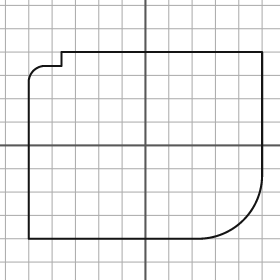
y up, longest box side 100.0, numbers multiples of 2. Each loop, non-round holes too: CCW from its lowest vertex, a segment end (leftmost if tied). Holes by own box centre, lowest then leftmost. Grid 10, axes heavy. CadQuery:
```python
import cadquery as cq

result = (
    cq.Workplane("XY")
    .moveTo(-50.0, -40.0)
    .lineTo(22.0, -40.0)
    .threePointArc((42.0, -32.0), (50.0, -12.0))
    .lineTo(50.0, 40.0)
    .lineTo(-36.0, 40.0)
    .lineTo(-36.0, 34.0)
    .lineTo(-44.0, 34.0)
    .threePointArc((-48.0, 32.0), (-50.0, 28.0))
    .close()
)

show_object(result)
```